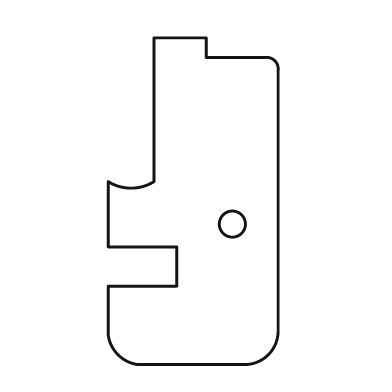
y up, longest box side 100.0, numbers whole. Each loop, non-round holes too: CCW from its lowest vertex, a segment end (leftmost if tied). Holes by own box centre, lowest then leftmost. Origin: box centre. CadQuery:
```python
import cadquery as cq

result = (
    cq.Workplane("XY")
    .moveTo(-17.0, -50.0)
    .lineTo(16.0, -50.0)
    .threePointArc((23.0, -47.0), (26.0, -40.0))
    .lineTo(26.0, 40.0)
    .threePointArc((25.0, 43.0), (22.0, 44.0))
    .lineTo(4.0, 44.0)
    .lineTo(4.0, 50.0)
    .lineTo(-12.0, 50.0)
    .lineTo(-12.0, 6.0)
    .threePointArc((-19.0, 4.0), (-26.0, 6.0))
    .lineTo(-26.0, -14.0)
    .lineTo(-5.0, -14.0)
    .lineTo(-5.0, -26.0)
    .lineTo(-26.0, -26.0)
    .lineTo(-26.0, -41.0)
    .threePointArc((-23.0, -47.0), (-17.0, -50.0))
    .close()
    .moveTo(12.0, -7.0)
    .circle(4.0)
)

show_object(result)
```